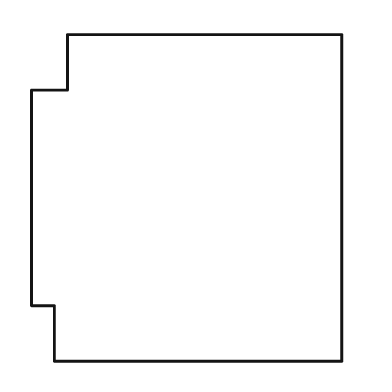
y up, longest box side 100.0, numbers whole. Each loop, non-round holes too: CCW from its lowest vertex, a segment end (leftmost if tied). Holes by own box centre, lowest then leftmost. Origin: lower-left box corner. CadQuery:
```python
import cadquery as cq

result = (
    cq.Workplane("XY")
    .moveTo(7.0, 0.0)
    .lineTo(95.0, 0.0)
    .lineTo(95.0, 100.0)
    .lineTo(11.0, 100.0)
    .lineTo(11.0, 83.0)
    .lineTo(0.0, 83.0)
    .lineTo(0.0, 17.0)
    .lineTo(7.0, 17.0)
    .close()
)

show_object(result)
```